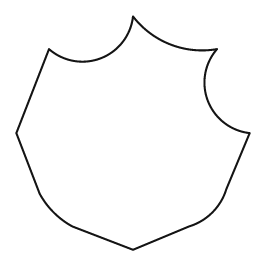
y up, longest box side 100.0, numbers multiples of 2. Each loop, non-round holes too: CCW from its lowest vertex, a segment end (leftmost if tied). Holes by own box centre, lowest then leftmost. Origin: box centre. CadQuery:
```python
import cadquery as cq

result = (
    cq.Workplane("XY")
    .moveTo(0.0, -50.0)
    .lineTo(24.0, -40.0)
    .threePointArc((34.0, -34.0), (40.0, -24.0))
    .lineTo(50.0, 0.0)
    .threePointArc((32.0, 14.0), (36.0, 36.0))
    .threePointArc((16.0, 38.0), (0.0, 50.0))
    .threePointArc((-14.0, 32.0), (-36.0, 36.0))
    .lineTo(-50.0, 0.0)
    .lineTo(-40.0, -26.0)
    .threePointArc((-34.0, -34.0), (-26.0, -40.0))
    .close()
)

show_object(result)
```